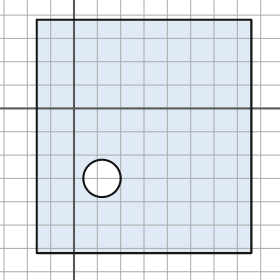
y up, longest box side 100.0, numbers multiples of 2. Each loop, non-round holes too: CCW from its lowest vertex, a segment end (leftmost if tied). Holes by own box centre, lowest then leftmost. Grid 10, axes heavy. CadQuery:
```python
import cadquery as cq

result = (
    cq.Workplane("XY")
    .moveTo(-16.0, -62.0)
    .lineTo(76.0, -62.0)
    .lineTo(76.0, 38.0)
    .lineTo(-16.0, 38.0)
    .close()
    .moveTo(12.0, -30.0)
    .circle(8.0)
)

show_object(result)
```